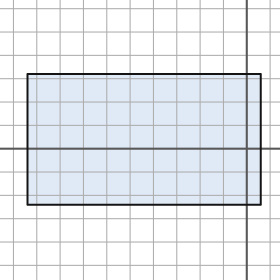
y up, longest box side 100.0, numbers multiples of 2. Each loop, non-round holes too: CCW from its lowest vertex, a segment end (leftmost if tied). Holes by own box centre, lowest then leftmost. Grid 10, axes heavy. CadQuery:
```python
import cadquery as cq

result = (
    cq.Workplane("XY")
    .moveTo(-94.0, -24.0)
    .lineTo(6.0, -24.0)
    .lineTo(6.0, 32.0)
    .lineTo(-94.0, 32.0)
    .close()
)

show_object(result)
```